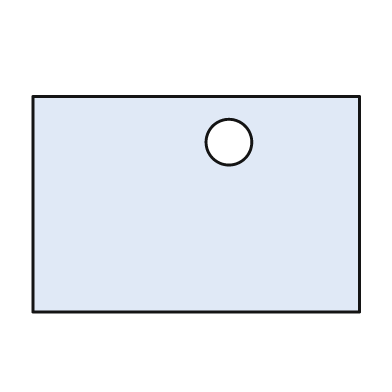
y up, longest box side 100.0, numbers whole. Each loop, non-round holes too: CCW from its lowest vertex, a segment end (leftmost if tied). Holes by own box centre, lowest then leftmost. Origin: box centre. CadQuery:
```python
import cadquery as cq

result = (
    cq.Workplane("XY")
    .moveTo(-50.0, -33.0)
    .lineTo(50.0, -33.0)
    .lineTo(50.0, 33.0)
    .lineTo(-50.0, 33.0)
    .close()
    .moveTo(10.0, 19.0)
    .circle(7.0)
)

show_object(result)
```